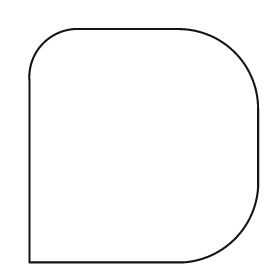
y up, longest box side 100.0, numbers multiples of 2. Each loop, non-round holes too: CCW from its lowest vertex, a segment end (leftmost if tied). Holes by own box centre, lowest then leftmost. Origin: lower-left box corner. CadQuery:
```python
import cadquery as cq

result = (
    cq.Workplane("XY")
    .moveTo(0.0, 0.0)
    .lineTo(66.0, 0.0)
    .threePointArc((88.0, 10.0), (98.0, 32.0))
    .lineTo(98.0, 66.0)
    .threePointArc((88.0, 90.0), (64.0, 100.0))
    .lineTo(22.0, 100.0)
    .threePointArc((6.0, 94.0), (0.0, 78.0))
    .close()
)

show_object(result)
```